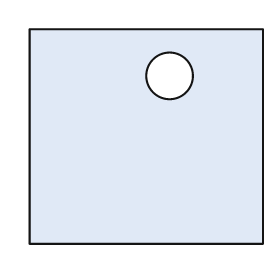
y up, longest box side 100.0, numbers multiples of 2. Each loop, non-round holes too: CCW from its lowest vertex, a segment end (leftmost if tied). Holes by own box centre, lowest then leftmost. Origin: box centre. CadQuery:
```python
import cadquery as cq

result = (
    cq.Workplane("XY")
    .moveTo(-50.0, -46.0)
    .lineTo(50.0, -46.0)
    .lineTo(50.0, 46.0)
    .lineTo(-50.0, 46.0)
    .close()
    .moveTo(10.0, 26.0)
    .circle(10.0)
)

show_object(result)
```